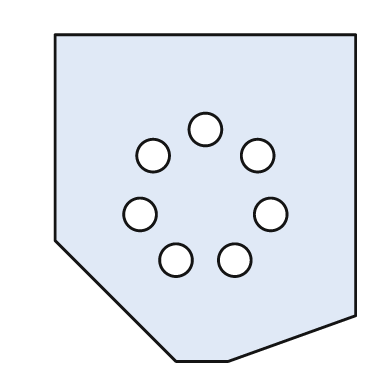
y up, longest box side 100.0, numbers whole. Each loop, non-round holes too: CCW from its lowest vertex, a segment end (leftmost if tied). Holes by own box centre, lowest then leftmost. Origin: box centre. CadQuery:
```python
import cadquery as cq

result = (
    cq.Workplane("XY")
    .moveTo(-9.0, -50.0)
    .lineTo(7.0, -50.0)
    .lineTo(46.0, -36.0)
    .lineTo(46.0, 50.0)
    .lineTo(-46.0, 50.0)
    .lineTo(-46.0, -13.0)
    .close()
    .moveTo(-9.0, -19.0)
    .circle(5.0)
    .moveTo(9.0, -19.0)
    .circle(5.0)
    .moveTo(-20.0, -5.0)
    .circle(5.0)
    .moveTo(20.0, -5.0)
    .circle(5.0)
    .moveTo(-16.0, 13.0)
    .circle(5.0)
    .moveTo(16.0, 13.0)
    .circle(5.0)
    .moveTo(0.0, 21.0)
    .circle(5.0)
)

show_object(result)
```